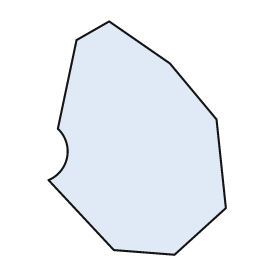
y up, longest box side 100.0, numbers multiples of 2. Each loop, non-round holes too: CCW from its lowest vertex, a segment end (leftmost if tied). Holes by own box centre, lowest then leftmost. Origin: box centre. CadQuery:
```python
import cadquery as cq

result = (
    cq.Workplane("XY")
    .moveTo(16.0, -50.0)
    .lineTo(38.0, -30.0)
    .lineTo(34.0, 8.0)
    .lineTo(14.0, 32.0)
    .lineTo(-12.0, 50.0)
    .lineTo(-26.0, 42.0)
    .lineTo(-34.0, 4.0)
    .threePointArc((-30.0, -8.0), (-38.0, -18.0))
    .lineTo(-10.0, -48.0)
    .close()
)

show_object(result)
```